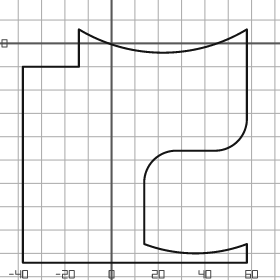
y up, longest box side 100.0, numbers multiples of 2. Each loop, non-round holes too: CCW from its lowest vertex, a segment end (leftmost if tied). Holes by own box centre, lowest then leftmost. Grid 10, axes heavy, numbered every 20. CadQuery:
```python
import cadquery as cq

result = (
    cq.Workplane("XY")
    .moveTo(-38.0, -94.0)
    .lineTo(58.0, -94.0)
    .lineTo(58.0, -86.0)
    .threePointArc((36.0, -90.0), (14.0, -86.0))
    .lineTo(14.0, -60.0)
    .threePointArc((18.0, -50.0), (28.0, -46.0))
    .lineTo(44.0, -46.0)
    .threePointArc((54.0, -42.0), (58.0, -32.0))
    .lineTo(58.0, 6.0)
    .threePointArc((22.0, -4.0), (-14.0, 6.0))
    .lineTo(-14.0, -10.0)
    .lineTo(-38.0, -10.0)
    .close()
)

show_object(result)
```